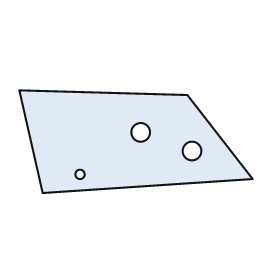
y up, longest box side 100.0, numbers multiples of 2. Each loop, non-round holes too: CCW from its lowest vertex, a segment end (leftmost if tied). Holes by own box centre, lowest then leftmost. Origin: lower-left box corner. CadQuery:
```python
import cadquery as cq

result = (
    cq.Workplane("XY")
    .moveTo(10.0, 0.0)
    .lineTo(100.0, 6.0)
    .lineTo(72.0, 42.0)
    .lineTo(0.0, 44.0)
    .close()
    .moveTo(26.0, 8.0)
    .circle(2.0)
    .moveTo(74.0, 18.0)
    .circle(4.0)
    .moveTo(52.0, 26.0)
    .circle(4.0)
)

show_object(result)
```